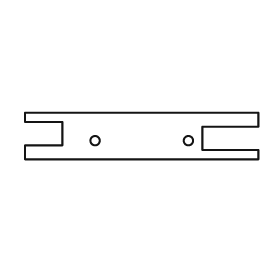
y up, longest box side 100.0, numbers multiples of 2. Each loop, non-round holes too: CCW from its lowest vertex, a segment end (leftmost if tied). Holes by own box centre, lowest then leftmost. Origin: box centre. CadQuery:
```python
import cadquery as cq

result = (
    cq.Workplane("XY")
    .moveTo(-50.0, -10.0)
    .lineTo(50.0, -10.0)
    .lineTo(50.0, -6.0)
    .lineTo(26.0, -6.0)
    .lineTo(26.0, 4.0)
    .lineTo(50.0, 4.0)
    .lineTo(50.0, 10.0)
    .lineTo(-50.0, 10.0)
    .lineTo(-50.0, 6.0)
    .lineTo(-34.0, 6.0)
    .lineTo(-34.0, -4.0)
    .lineTo(-50.0, -4.0)
    .close()
    .moveTo(-20.0, -2.0)
    .circle(2.0)
    .moveTo(20.0, -2.0)
    .circle(2.0)
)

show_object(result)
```